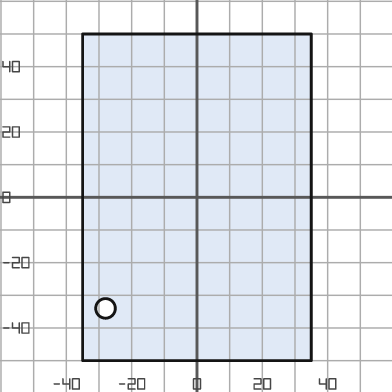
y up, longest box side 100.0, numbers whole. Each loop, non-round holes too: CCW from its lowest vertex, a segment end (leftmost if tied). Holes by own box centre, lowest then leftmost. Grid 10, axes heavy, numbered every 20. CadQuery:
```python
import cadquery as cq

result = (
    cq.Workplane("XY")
    .moveTo(-35.0, -50.0)
    .lineTo(35.0, -50.0)
    .lineTo(35.0, 50.0)
    .lineTo(-35.0, 50.0)
    .close()
    .moveTo(-28.0, -34.0)
    .circle(3.0)
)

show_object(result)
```